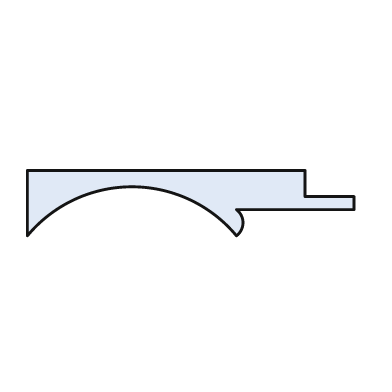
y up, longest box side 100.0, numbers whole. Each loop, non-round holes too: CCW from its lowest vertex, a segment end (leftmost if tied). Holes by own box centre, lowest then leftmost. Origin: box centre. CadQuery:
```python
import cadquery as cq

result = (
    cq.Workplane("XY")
    .moveTo(-50.0, -10.0)
    .threePointArc((-18.0, 5.0), (14.0, -10.0))
    .threePointArc((16.0, -6.0), (14.0, -2.0))
    .lineTo(50.0, -2.0)
    .lineTo(50.0, 2.0)
    .lineTo(35.0, 2.0)
    .lineTo(35.0, 10.0)
    .lineTo(-50.0, 10.0)
    .close()
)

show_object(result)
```